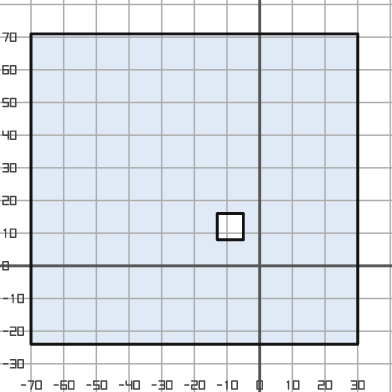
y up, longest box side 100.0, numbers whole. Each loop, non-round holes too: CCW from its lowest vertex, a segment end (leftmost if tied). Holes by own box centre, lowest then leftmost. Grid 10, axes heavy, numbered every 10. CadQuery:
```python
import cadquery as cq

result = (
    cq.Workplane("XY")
    .moveTo(-70.0, -24.0)
    .lineTo(30.0, -24.0)
    .lineTo(30.0, 71.0)
    .lineTo(-70.0, 71.0)
    .close()
    .moveTo(-13.0, 8.0)
    .lineTo(-5.0, 8.0)
    .lineTo(-5.0, 16.0)
    .lineTo(-13.0, 16.0)
    .close()
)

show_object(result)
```